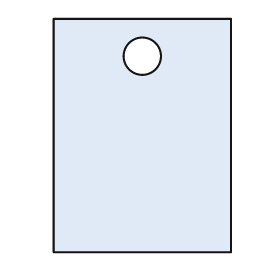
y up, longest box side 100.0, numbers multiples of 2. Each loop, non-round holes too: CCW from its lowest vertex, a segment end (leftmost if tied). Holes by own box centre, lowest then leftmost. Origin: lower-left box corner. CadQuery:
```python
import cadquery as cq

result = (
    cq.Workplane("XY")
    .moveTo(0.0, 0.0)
    .lineTo(76.0, 0.0)
    .lineTo(76.0, 100.0)
    .lineTo(0.0, 100.0)
    .close()
    .moveTo(38.0, 84.0)
    .circle(8.0)
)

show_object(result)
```